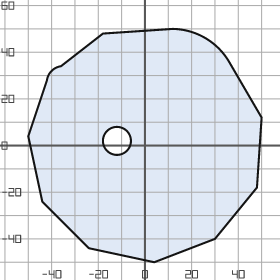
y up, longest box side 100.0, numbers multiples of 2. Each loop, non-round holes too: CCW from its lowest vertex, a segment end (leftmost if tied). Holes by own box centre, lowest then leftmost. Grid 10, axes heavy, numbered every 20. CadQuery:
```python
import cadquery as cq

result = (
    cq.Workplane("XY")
    .moveTo(4.0, -50.0)
    .lineTo(30.0, -40.0)
    .lineTo(48.0, -18.0)
    .lineTo(50.0, 12.0)
    .lineTo(36.0, 36.0)
    .threePointArc((26.0, 46.0), (12.0, 50.0))
    .lineTo(-18.0, 48.0)
    .lineTo(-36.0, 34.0)
    .threePointArc((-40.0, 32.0), (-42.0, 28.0))
    .lineTo(-50.0, 4.0)
    .lineTo(-44.0, -24.0)
    .lineTo(-24.0, -44.0)
    .close()
    .moveTo(-12.0, 2.0)
    .circle(6.0)
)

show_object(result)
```